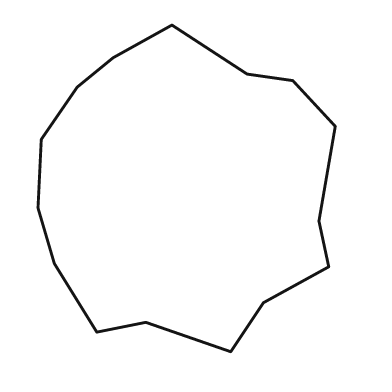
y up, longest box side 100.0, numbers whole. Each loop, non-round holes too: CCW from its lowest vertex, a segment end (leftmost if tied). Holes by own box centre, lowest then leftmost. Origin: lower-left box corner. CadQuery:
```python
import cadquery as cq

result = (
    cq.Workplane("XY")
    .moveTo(59.0, 0.0)
    .lineTo(69.0, 15.0)
    .lineTo(89.0, 26.0)
    .lineTo(86.0, 40.0)
    .lineTo(91.0, 69.0)
    .lineTo(78.0, 83.0)
    .lineTo(64.0, 85.0)
    .lineTo(41.0, 100.0)
    .lineTo(23.0, 90.0)
    .lineTo(12.0, 81.0)
    .lineTo(1.0, 65.0)
    .lineTo(0.0, 44.0)
    .lineTo(5.0, 27.0)
    .lineTo(18.0, 6.0)
    .lineTo(33.0, 9.0)
    .close()
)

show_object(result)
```